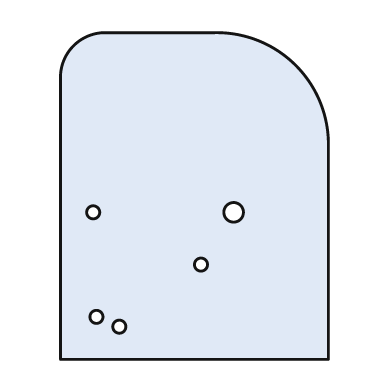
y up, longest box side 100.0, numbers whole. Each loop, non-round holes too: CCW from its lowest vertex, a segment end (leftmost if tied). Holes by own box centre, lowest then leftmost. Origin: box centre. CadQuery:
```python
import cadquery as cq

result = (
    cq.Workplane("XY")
    .moveTo(-41.0, -50.0)
    .lineTo(41.0, -50.0)
    .lineTo(41.0, 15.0)
    .threePointArc((31.0, 40.0), (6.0, 50.0))
    .lineTo(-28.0, 50.0)
    .threePointArc((-37.0, 46.0), (-41.0, 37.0))
    .close()
    .moveTo(-23.0, -40.0)
    .circle(2.0)
    .moveTo(-30.0, -37.0)
    .circle(2.0)
    .moveTo(2.0, -21.0)
    .circle(2.0)
    .moveTo(-31.0, -5.0)
    .circle(2.0)
    .moveTo(12.0, -5.0)
    .circle(3.0)
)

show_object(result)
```